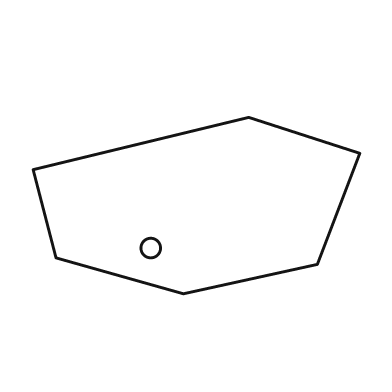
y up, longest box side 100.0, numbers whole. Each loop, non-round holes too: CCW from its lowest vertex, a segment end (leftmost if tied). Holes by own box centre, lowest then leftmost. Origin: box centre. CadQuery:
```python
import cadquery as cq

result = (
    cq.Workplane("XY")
    .moveTo(-4.0, -27.0)
    .lineTo(37.0, -18.0)
    .lineTo(50.0, 16.0)
    .lineTo(16.0, 27.0)
    .lineTo(-50.0, 11.0)
    .lineTo(-43.0, -16.0)
    .close()
    .moveTo(-14.0, -13.0)
    .circle(3.0)
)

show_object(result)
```